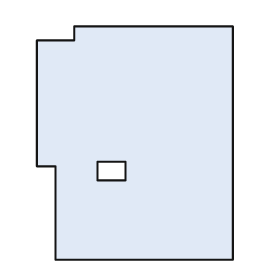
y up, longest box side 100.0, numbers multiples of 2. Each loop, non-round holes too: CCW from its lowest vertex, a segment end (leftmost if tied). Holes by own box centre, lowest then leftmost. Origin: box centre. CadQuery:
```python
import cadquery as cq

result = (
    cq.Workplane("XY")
    .moveTo(-34.0, -50.0)
    .lineTo(42.0, -50.0)
    .lineTo(42.0, 50.0)
    .lineTo(-26.0, 50.0)
    .lineTo(-26.0, 44.0)
    .lineTo(-42.0, 44.0)
    .lineTo(-42.0, -10.0)
    .lineTo(-34.0, -10.0)
    .close()
    .moveTo(-16.0, -16.0)
    .lineTo(-4.0, -16.0)
    .lineTo(-4.0, -8.0)
    .lineTo(-16.0, -8.0)
    .close()
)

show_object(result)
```